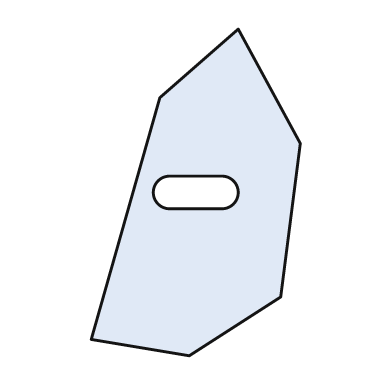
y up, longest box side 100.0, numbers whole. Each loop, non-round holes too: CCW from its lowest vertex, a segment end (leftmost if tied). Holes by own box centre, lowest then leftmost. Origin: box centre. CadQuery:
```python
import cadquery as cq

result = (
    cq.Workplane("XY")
    .moveTo(-2.0, -50.0)
    .lineTo(26.0, -32.0)
    .lineTo(32.0, 15.0)
    .lineTo(13.0, 50.0)
    .lineTo(-11.0, 29.0)
    .lineTo(-32.0, -45.0)
    .close()
    .moveTo(-8.0, -5.0)
    .lineTo(8.0, -5.0)
    .threePointArc((13.0, 0.0), (8.0, 5.0))
    .lineTo(-8.0, 5.0)
    .threePointArc((-13.0, 0.0), (-8.0, -5.0))
    .close()
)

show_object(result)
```